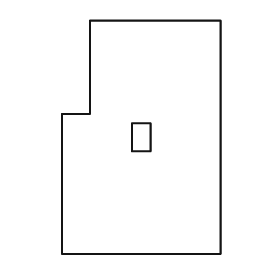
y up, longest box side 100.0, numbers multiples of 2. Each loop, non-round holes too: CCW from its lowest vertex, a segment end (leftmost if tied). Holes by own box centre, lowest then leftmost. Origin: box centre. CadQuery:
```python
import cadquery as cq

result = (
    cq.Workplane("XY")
    .moveTo(-34.0, -50.0)
    .lineTo(34.0, -50.0)
    .lineTo(34.0, 50.0)
    .lineTo(-22.0, 50.0)
    .lineTo(-22.0, 10.0)
    .lineTo(-34.0, 10.0)
    .close()
    .moveTo(-4.0, -6.0)
    .lineTo(4.0, -6.0)
    .lineTo(4.0, 6.0)
    .lineTo(-4.0, 6.0)
    .close()
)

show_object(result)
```